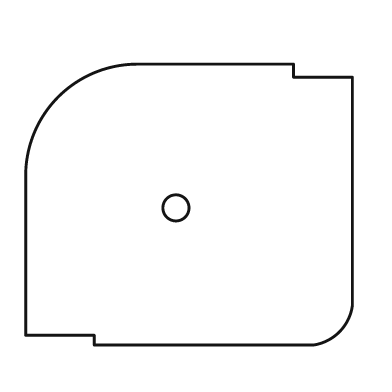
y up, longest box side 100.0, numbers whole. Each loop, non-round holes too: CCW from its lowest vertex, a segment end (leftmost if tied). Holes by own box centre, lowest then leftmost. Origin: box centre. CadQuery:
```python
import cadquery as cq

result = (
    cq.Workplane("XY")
    .moveTo(-29.0, -43.0)
    .lineTo(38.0, -43.0)
    .threePointArc((46.0, -39.0), (50.0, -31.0))
    .lineTo(50.0, 39.0)
    .lineTo(32.0, 39.0)
    .lineTo(32.0, 43.0)
    .lineTo(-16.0, 43.0)
    .threePointArc((-40.0, 33.0), (-50.0, 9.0))
    .lineTo(-50.0, -40.0)
    .lineTo(-29.0, -40.0)
    .close()
    .moveTo(-4.0, -1.0)
    .circle(4.0)
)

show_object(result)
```